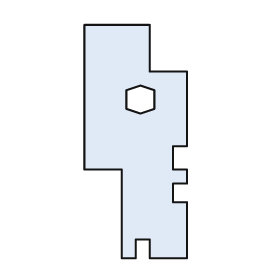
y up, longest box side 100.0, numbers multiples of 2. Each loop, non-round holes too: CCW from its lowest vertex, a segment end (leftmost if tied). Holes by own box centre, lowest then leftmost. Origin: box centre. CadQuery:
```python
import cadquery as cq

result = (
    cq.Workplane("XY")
    .moveTo(-6.0, -50.0)
    .lineTo(0.0, -50.0)
    .lineTo(0.0, -42.0)
    .lineTo(6.0, -42.0)
    .lineTo(6.0, -50.0)
    .lineTo(22.0, -50.0)
    .lineTo(22.0, -26.0)
    .lineTo(16.0, -26.0)
    .lineTo(16.0, -18.0)
    .lineTo(22.0, -18.0)
    .lineTo(22.0, -12.0)
    .lineTo(16.0, -12.0)
    .lineTo(16.0, -2.0)
    .lineTo(22.0, -2.0)
    .lineTo(22.0, 30.0)
    .lineTo(6.0, 30.0)
    .lineTo(6.0, 50.0)
    .lineTo(-22.0, 50.0)
    .lineTo(-22.0, -12.0)
    .lineTo(-6.0, -12.0)
    .close()
    .moveTo(2.0, 12.0)
    .lineTo(8.0, 14.0)
    .lineTo(8.0, 22.0)
    .lineTo(2.0, 24.0)
    .lineTo(-4.0, 22.0)
    .lineTo(-4.0, 14.0)
    .close()
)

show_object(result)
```